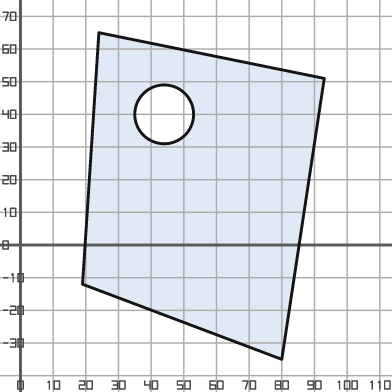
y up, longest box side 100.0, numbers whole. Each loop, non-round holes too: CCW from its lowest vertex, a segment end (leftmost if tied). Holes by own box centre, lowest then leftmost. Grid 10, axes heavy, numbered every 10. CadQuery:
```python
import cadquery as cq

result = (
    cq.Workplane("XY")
    .moveTo(80.0, -35.0)
    .lineTo(93.0, 51.0)
    .lineTo(24.0, 65.0)
    .lineTo(19.0, -12.0)
    .close()
    .moveTo(44.0, 40.0)
    .circle(9.0)
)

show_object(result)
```